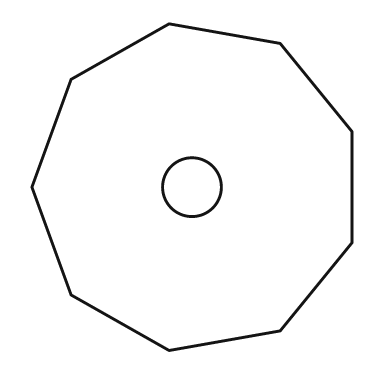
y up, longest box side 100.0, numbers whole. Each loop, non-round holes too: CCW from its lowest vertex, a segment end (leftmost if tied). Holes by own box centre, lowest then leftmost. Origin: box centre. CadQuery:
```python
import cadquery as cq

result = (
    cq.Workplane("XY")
    .moveTo(-7.0, -50.0)
    .lineTo(27.0, -44.0)
    .lineTo(49.0, -17.0)
    .lineTo(49.0, 17.0)
    .lineTo(27.0, 44.0)
    .lineTo(-7.0, 50.0)
    .lineTo(-37.0, 33.0)
    .lineTo(-49.0, 0.0)
    .lineTo(-37.0, -33.0)
    .close()
    .moveTo(0.0, 0.0)
    .circle(9.0)
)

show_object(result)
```